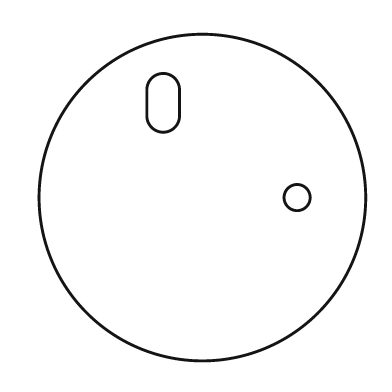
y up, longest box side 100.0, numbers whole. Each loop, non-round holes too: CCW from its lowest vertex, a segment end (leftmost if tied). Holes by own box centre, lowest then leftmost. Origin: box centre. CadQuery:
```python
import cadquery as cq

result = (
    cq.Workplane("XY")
    .moveTo(0.0, 0.0)
    .circle(50.0)
    .moveTo(29.0, 0.0)
    .circle(4.0)
    .moveTo(-17.0, 25.0)
    .threePointArc((-12.0, 20.0), (-7.0, 25.0))
    .lineTo(-7.0, 33.0)
    .threePointArc((-12.0, 38.0), (-17.0, 33.0))
    .close()
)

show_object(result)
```